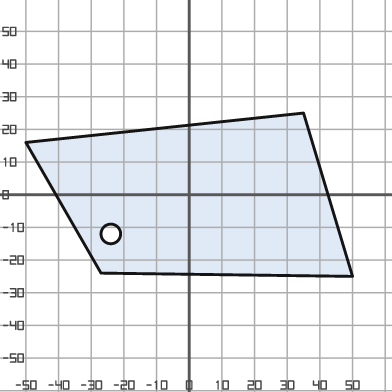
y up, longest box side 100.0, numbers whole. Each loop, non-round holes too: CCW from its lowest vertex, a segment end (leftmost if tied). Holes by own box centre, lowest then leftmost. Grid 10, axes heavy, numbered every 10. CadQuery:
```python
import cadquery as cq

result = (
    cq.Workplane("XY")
    .moveTo(50.0, -25.0)
    .lineTo(35.0, 25.0)
    .lineTo(-50.0, 16.0)
    .lineTo(-27.0, -24.0)
    .close()
    .moveTo(-24.0, -12.0)
    .circle(3.0)
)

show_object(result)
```